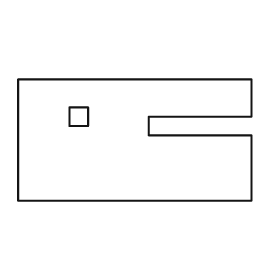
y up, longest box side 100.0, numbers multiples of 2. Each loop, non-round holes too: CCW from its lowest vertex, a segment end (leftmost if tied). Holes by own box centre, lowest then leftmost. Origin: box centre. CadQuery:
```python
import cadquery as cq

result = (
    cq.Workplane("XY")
    .moveTo(-50.0, -26.0)
    .lineTo(50.0, -26.0)
    .lineTo(50.0, 2.0)
    .lineTo(6.0, 2.0)
    .lineTo(6.0, 10.0)
    .lineTo(50.0, 10.0)
    .lineTo(50.0, 26.0)
    .lineTo(-50.0, 26.0)
    .close()
    .moveTo(-28.0, 6.0)
    .lineTo(-20.0, 6.0)
    .lineTo(-20.0, 14.0)
    .lineTo(-28.0, 14.0)
    .close()
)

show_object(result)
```